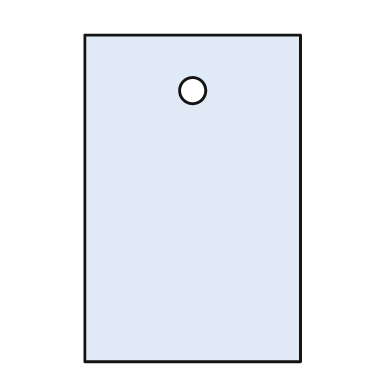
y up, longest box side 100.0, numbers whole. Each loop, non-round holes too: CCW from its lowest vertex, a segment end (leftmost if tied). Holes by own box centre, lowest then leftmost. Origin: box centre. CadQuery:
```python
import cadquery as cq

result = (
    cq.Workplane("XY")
    .moveTo(-33.0, -50.0)
    .lineTo(33.0, -50.0)
    .lineTo(33.0, 50.0)
    .lineTo(-33.0, 50.0)
    .close()
    .moveTo(0.0, 33.0)
    .circle(4.0)
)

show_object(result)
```